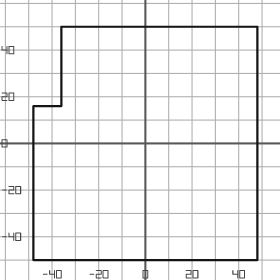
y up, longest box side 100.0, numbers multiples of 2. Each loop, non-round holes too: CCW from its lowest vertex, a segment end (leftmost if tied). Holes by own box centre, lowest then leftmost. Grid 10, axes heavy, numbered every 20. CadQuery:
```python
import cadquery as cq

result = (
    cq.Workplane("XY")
    .moveTo(-48.0, -50.0)
    .lineTo(48.0, -50.0)
    .lineTo(48.0, 50.0)
    .lineTo(-36.0, 50.0)
    .lineTo(-36.0, 16.0)
    .lineTo(-48.0, 16.0)
    .close()
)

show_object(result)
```